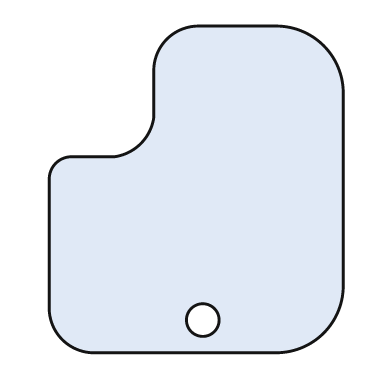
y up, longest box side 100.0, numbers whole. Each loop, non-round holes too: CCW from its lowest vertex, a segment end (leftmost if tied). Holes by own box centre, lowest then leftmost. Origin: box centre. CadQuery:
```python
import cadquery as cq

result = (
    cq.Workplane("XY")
    .moveTo(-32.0, -50.0)
    .lineTo(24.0, -50.0)
    .threePointArc((39.0, -44.0), (45.0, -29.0))
    .lineTo(45.0, 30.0)
    .threePointArc((39.0, 44.0), (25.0, 50.0))
    .lineTo(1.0, 50.0)
    .threePointArc((-9.0, 46.0), (-13.0, 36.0))
    .lineTo(-13.0, 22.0)
    .threePointArc((-17.0, 14.0), (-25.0, 10.0))
    .lineTo(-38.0, 10.0)
    .threePointArc((-43.0, 8.0), (-45.0, 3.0))
    .lineTo(-45.0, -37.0)
    .threePointArc((-41.0, -46.0), (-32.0, -50.0))
    .close()
    .moveTo(2.0, -40.0)
    .circle(5.0)
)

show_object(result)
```